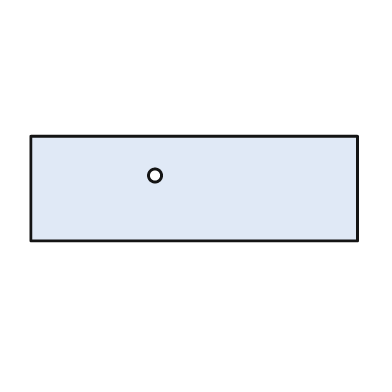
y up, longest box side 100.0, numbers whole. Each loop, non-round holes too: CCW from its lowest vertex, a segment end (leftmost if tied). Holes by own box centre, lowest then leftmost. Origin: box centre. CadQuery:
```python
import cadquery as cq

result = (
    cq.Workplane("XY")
    .moveTo(-50.0, -16.0)
    .lineTo(50.0, -16.0)
    .lineTo(50.0, 16.0)
    .lineTo(-50.0, 16.0)
    .close()
    .moveTo(-12.0, 4.0)
    .circle(2.0)
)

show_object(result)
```